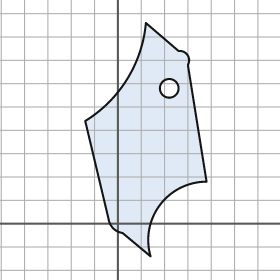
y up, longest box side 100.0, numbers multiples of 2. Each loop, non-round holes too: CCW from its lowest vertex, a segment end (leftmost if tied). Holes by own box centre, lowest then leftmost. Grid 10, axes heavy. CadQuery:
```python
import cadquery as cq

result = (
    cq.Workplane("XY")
    .moveTo(14.0, -14.0)
    .threePointArc((18.0, 8.0), (38.0, 18.0))
    .lineTo(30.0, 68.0)
    .threePointArc((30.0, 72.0), (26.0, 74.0))
    .lineTo(12.0, 86.0)
    .threePointArc((4.0, 62.0), (-14.0, 44.0))
    .lineTo(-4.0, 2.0)
    .threePointArc((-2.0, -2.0), (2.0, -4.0))
    .close()
    .moveTo(22.0, 58.0)
    .circle(4.0)
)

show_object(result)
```